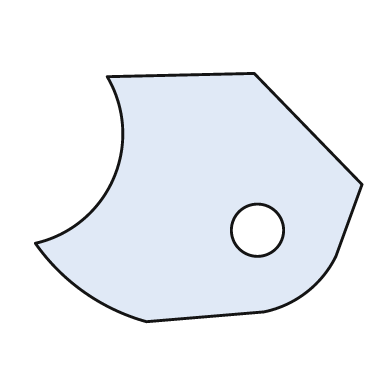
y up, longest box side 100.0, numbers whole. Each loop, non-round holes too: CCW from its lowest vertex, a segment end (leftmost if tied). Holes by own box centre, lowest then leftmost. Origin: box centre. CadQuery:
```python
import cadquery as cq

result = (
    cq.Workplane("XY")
    .moveTo(-16.0, -38.0)
    .lineTo(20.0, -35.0)
    .threePointArc((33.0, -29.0), (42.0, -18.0))
    .lineTo(50.0, 4.0)
    .lineTo(17.0, 38.0)
    .lineTo(-28.0, 37.0)
    .threePointArc((-26.0, 6.0), (-50.0, -14.0))
    .threePointArc((-35.0, -29.0), (-16.0, -38.0))
    .close()
    .moveTo(18.0, -10.0)
    .circle(8.0)
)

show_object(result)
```